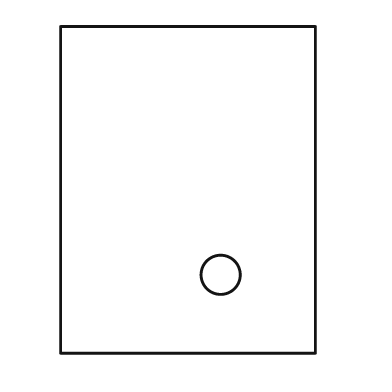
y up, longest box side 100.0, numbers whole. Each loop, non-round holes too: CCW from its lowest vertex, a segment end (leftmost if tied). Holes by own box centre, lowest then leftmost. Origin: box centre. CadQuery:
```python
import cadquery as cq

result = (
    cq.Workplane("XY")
    .moveTo(-39.0, -50.0)
    .lineTo(39.0, -50.0)
    .lineTo(39.0, 50.0)
    .lineTo(-39.0, 50.0)
    .close()
    .moveTo(10.0, -26.0)
    .circle(6.0)
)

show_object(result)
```